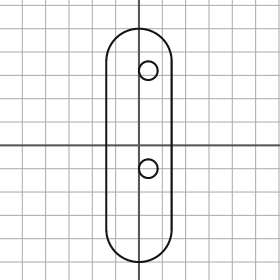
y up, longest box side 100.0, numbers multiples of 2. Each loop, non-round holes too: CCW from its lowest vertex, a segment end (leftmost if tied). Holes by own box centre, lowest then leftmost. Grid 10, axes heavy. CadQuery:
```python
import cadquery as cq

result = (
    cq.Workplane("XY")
    .moveTo(-14.0, -36.0)
    .threePointArc((0.0, -50.0), (14.0, -36.0))
    .lineTo(14.0, 36.0)
    .threePointArc((0.0, 50.0), (-14.0, 36.0))
    .close()
    .moveTo(4.0, -10.0)
    .circle(4.0)
    .moveTo(4.0, 32.0)
    .circle(4.0)
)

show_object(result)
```